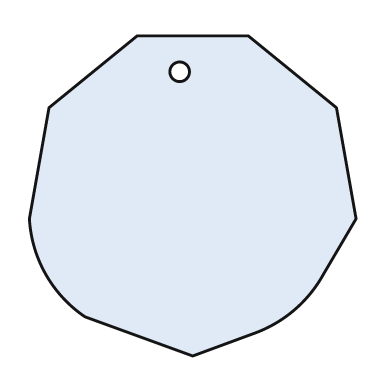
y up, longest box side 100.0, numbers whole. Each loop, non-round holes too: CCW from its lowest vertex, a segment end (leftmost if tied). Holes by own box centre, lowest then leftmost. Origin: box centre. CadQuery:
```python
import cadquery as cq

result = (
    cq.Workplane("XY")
    .moveTo(0.0, -49.0)
    .lineTo(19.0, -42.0)
    .threePointArc((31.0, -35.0), (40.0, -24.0))
    .lineTo(50.0, -7.0)
    .lineTo(44.0, 27.0)
    .lineTo(17.0, 49.0)
    .lineTo(-17.0, 49.0)
    .lineTo(-44.0, 27.0)
    .lineTo(-50.0, -7.0)
    .threePointArc((-45.0, -24.0), (-33.0, -37.0))
    .close()
    .moveTo(-4.0, 38.0)
    .circle(3.0)
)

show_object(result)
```